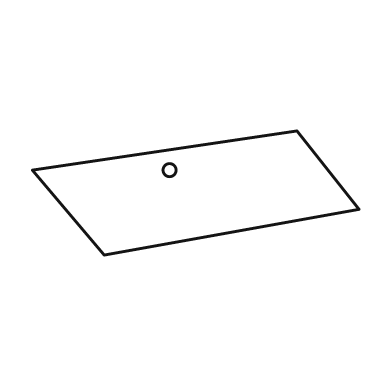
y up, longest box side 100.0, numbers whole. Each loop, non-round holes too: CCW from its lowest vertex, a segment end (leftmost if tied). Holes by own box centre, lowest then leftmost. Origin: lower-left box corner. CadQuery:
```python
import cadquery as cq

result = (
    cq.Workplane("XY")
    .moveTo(22.0, 0.0)
    .lineTo(100.0, 14.0)
    .lineTo(81.0, 38.0)
    .lineTo(0.0, 26.0)
    .close()
    .moveTo(42.0, 26.0)
    .circle(2.0)
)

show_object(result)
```